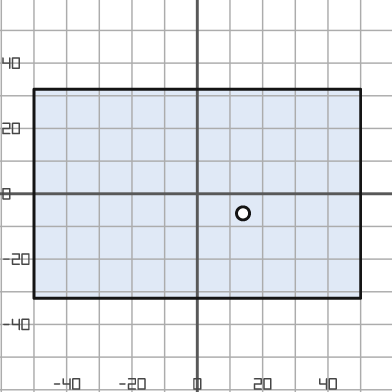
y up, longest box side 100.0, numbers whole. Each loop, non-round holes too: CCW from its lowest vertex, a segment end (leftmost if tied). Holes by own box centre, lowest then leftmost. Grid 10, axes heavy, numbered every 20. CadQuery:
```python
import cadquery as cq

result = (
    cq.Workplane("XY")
    .moveTo(-50.0, -32.0)
    .lineTo(50.0, -32.0)
    .lineTo(50.0, 32.0)
    .lineTo(-50.0, 32.0)
    .close()
    .moveTo(14.0, -6.0)
    .circle(2.0)
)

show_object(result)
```